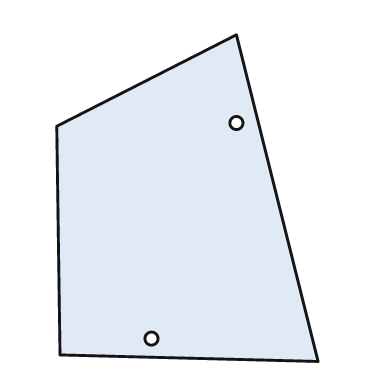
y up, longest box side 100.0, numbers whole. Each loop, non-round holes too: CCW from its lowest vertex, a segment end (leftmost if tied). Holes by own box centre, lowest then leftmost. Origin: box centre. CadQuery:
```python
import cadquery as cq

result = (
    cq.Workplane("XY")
    .moveTo(40.0, -50.0)
    .lineTo(15.0, 50.0)
    .lineTo(-40.0, 22.0)
    .lineTo(-39.0, -48.0)
    .close()
    .moveTo(-11.0, -43.0)
    .circle(2.0)
    .moveTo(15.0, 23.0)
    .circle(2.0)
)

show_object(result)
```